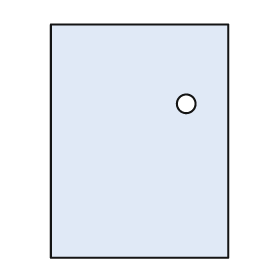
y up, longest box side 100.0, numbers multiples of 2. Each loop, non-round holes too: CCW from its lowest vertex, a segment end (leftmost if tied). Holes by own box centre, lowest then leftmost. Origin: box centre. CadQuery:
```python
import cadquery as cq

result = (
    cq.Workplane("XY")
    .moveTo(-38.0, -50.0)
    .lineTo(38.0, -50.0)
    .lineTo(38.0, 50.0)
    .lineTo(-38.0, 50.0)
    .close()
    .moveTo(20.0, 16.0)
    .circle(4.0)
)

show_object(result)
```